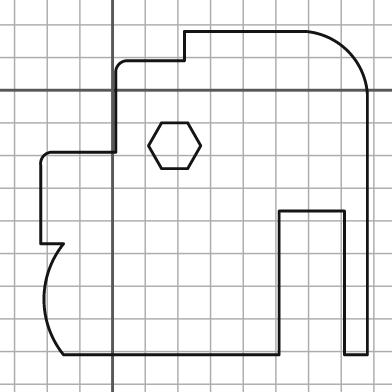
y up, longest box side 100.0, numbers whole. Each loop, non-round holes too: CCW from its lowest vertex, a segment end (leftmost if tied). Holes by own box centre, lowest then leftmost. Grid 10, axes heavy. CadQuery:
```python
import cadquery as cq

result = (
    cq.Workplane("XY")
    .moveTo(-15.0, -81.0)
    .lineTo(51.0, -81.0)
    .lineTo(51.0, -37.0)
    .lineTo(71.0, -37.0)
    .lineTo(71.0, -81.0)
    .lineTo(78.0, -81.0)
    .lineTo(78.0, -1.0)
    .threePointArc((72.0, 12.0), (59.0, 18.0))
    .lineTo(22.0, 18.0)
    .lineTo(22.0, 9.0)
    .lineTo(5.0, 9.0)
    .threePointArc((2.0, 8.0), (1.0, 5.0))
    .lineTo(1.0, -19.0)
    .lineTo(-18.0, -19.0)
    .threePointArc((-21.0, -20.0), (-22.0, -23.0))
    .lineTo(-22.0, -47.0)
    .lineTo(-15.0, -47.0)
    .threePointArc((-21.0, -64.0), (-15.0, -81.0))
    .close()
    .moveTo(15.0, -24.0)
    .lineTo(23.0, -24.0)
    .lineTo(27.0, -17.0)
    .lineTo(23.0, -10.0)
    .lineTo(15.0, -10.0)
    .lineTo(11.0, -17.0)
    .close()
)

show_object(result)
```